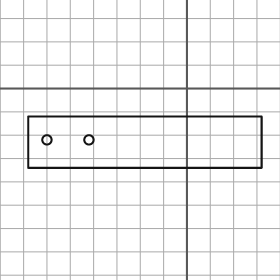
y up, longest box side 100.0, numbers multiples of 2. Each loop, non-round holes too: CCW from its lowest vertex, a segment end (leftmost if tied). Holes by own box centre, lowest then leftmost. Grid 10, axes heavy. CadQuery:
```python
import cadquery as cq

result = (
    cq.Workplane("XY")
    .moveTo(-68.0, -34.0)
    .lineTo(32.0, -34.0)
    .lineTo(32.0, -12.0)
    .lineTo(-68.0, -12.0)
    .close()
    .moveTo(-60.0, -22.0)
    .circle(2.0)
    .moveTo(-42.0, -22.0)
    .circle(2.0)
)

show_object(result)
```